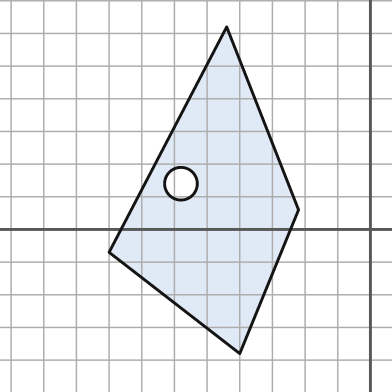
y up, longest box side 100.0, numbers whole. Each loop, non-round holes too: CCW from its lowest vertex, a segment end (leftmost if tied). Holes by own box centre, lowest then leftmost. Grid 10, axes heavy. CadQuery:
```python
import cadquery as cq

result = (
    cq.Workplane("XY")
    .moveTo(-40.0, -38.0)
    .lineTo(-22.0, 6.0)
    .lineTo(-44.0, 62.0)
    .lineTo(-80.0, -7.0)
    .close()
    .moveTo(-58.0, 14.0)
    .circle(5.0)
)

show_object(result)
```